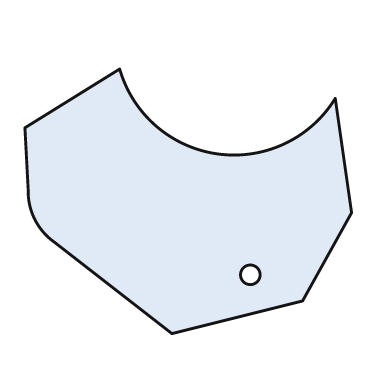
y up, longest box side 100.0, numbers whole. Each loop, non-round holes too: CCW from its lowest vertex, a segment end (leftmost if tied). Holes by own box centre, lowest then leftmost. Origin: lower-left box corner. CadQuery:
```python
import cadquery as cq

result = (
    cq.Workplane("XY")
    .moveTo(45.0, 0.0)
    .lineTo(85.0, 10.0)
    .lineTo(100.0, 37.0)
    .lineTo(95.0, 72.0)
    .threePointArc((59.0, 55.0), (29.0, 81.0))
    .lineTo(0.0, 63.0)
    .lineTo(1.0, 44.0)
    .threePointArc((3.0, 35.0), (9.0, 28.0))
    .close()
    .moveTo(69.0, 18.0)
    .circle(3.0)
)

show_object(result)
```